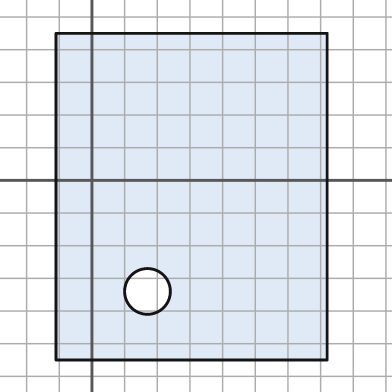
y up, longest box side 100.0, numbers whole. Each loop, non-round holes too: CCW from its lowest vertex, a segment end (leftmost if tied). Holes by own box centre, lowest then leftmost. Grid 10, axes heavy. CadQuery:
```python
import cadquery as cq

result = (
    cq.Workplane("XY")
    .moveTo(-11.0, -55.0)
    .lineTo(72.0, -55.0)
    .lineTo(72.0, 45.0)
    .lineTo(-11.0, 45.0)
    .close()
    .moveTo(17.0, -34.0)
    .circle(7.0)
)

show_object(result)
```